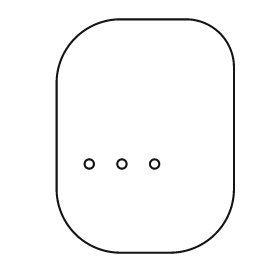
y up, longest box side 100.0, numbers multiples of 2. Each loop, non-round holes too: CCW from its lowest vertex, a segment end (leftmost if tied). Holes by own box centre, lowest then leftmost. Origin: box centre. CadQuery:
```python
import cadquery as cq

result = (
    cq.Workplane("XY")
    .moveTo(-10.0, -50.0)
    .lineTo(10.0, -50.0)
    .threePointArc((30.0, -42.0), (38.0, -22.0))
    .lineTo(38.0, 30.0)
    .threePointArc((32.0, 44.0), (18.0, 50.0))
    .lineTo(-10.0, 50.0)
    .threePointArc((-30.0, 42.0), (-38.0, 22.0))
    .lineTo(-38.0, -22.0)
    .threePointArc((-30.0, -42.0), (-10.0, -50.0))
    .close()
    .moveTo(-24.0, -12.0)
    .circle(2.0)
    .moveTo(-10.0, -12.0)
    .circle(2.0)
    .moveTo(4.0, -12.0)
    .circle(2.0)
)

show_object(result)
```